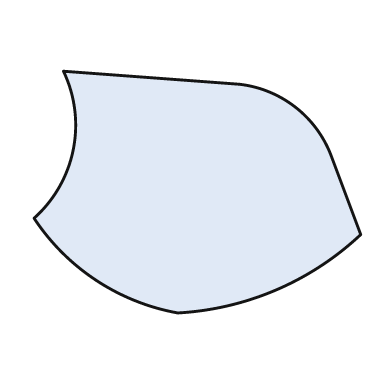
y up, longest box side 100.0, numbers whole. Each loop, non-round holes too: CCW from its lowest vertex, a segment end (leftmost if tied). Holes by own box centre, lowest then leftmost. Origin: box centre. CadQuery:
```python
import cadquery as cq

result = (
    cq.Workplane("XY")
    .moveTo(-6.0, -37.0)
    .threePointArc((24.0, -30.0), (50.0, -13.0))
    .lineTo(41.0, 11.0)
    .threePointArc((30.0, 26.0), (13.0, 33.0))
    .lineTo(-41.0, 37.0)
    .threePointArc((-38.0, 13.0), (-50.0, -8.0))
    .threePointArc((-31.0, -27.0), (-6.0, -37.0))
    .close()
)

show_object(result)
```